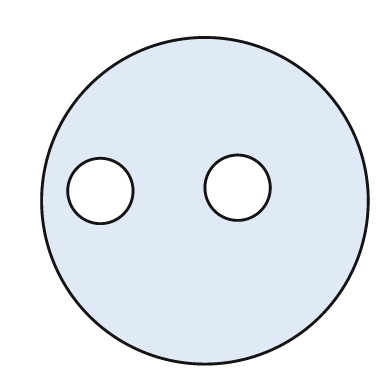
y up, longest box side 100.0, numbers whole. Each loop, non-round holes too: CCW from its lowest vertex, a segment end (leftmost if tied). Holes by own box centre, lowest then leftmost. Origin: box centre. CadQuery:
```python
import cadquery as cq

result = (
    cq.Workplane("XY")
    .moveTo(0.0, 0.0)
    .circle(50.0)
    .moveTo(-32.0, 3.0)
    .circle(10.0)
    .moveTo(10.0, 4.0)
    .circle(10.0)
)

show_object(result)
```